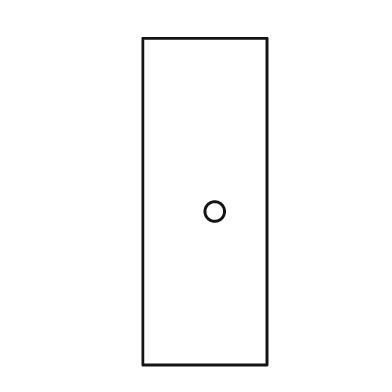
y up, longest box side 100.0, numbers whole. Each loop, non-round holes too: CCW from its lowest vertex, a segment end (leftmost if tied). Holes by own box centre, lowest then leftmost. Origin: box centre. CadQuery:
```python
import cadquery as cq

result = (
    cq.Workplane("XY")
    .moveTo(-19.0, -50.0)
    .lineTo(19.0, -50.0)
    .lineTo(19.0, 50.0)
    .lineTo(-19.0, 50.0)
    .close()
    .moveTo(3.0, -3.0)
    .circle(3.0)
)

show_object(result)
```